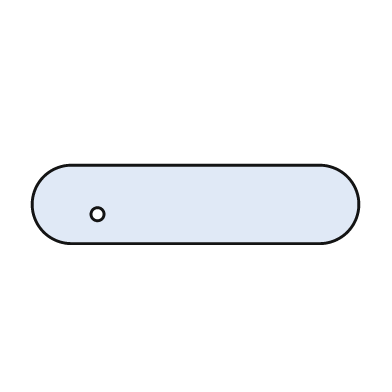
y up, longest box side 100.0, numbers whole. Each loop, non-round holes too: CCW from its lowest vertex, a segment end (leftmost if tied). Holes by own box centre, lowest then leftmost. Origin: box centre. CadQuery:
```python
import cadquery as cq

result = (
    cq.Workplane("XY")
    .moveTo(-38.0, -12.0)
    .lineTo(38.0, -12.0)
    .threePointArc((50.0, 0.0), (38.0, 12.0))
    .lineTo(-38.0, 12.0)
    .threePointArc((-50.0, 0.0), (-38.0, -12.0))
    .close()
    .moveTo(-30.0, -3.0)
    .circle(2.0)
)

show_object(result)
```